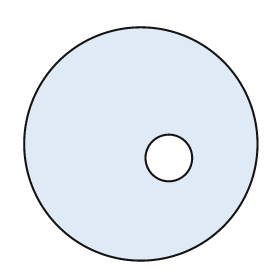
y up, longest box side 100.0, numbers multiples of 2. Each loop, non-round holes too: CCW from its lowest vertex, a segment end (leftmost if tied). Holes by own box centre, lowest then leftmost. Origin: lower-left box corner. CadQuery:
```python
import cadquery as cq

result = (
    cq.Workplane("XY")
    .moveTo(50.0, 50.0)
    .circle(50.0)
    .moveTo(62.0, 44.0)
    .circle(10.0)
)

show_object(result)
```